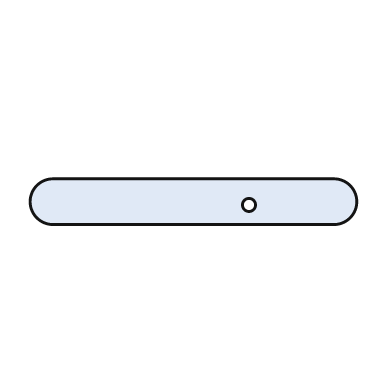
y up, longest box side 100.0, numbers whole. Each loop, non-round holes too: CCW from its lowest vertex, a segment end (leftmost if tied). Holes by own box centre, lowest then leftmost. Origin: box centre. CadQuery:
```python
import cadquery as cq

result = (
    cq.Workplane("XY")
    .moveTo(-43.0, -7.0)
    .lineTo(43.0, -7.0)
    .threePointArc((50.0, 0.0), (43.0, 7.0))
    .lineTo(-43.0, 7.0)
    .threePointArc((-50.0, 0.0), (-43.0, -7.0))
    .close()
    .moveTo(17.0, -1.0)
    .circle(2.0)
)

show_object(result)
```